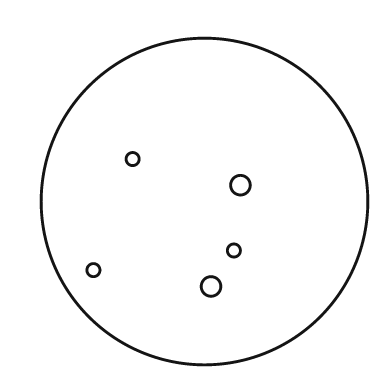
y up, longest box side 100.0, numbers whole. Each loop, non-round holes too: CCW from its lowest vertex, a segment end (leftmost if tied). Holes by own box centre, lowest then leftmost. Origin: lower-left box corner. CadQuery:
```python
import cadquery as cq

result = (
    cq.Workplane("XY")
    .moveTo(50.0, 50.0)
    .circle(50.0)
    .moveTo(52.0, 24.0)
    .circle(3.0)
    .moveTo(16.0, 29.0)
    .circle(2.0)
    .moveTo(59.0, 35.0)
    .circle(2.0)
    .moveTo(61.0, 55.0)
    .circle(3.0)
    .moveTo(28.0, 63.0)
    .circle(2.0)
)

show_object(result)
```